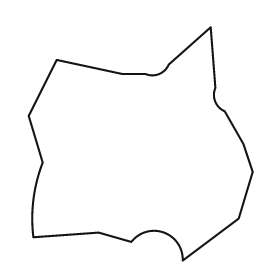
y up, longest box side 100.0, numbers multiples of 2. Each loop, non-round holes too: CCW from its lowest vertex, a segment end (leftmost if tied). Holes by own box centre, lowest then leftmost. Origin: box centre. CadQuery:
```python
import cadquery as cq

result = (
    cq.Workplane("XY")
    .moveTo(18.0, -50.0)
    .lineTo(42.0, -32.0)
    .lineTo(48.0, -12.0)
    .lineTo(44.0, 0.0)
    .lineTo(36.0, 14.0)
    .threePointArc((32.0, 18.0), (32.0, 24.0))
    .lineTo(30.0, 50.0)
    .lineTo(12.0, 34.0)
    .threePointArc((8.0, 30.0), (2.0, 30.0))
    .lineTo(-8.0, 30.0)
    .lineTo(-36.0, 36.0)
    .lineTo(-48.0, 12.0)
    .lineTo(-42.0, -8.0)
    .threePointArc((-46.0, -24.0), (-46.0, -40.0))
    .lineTo(-18.0, -38.0)
    .lineTo(-4.0, -42.0)
    .threePointArc((10.0, -38.0), (18.0, -50.0))
    .close()
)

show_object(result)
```